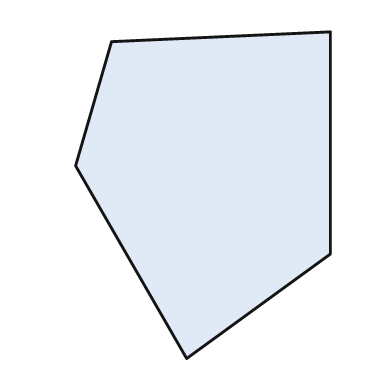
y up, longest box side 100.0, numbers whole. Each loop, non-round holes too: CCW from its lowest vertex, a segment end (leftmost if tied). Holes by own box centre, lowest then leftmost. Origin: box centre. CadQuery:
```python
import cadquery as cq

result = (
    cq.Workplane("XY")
    .moveTo(-5.0, -50.0)
    .lineTo(39.0, -18.0)
    .lineTo(39.0, 50.0)
    .lineTo(-28.0, 47.0)
    .lineTo(-39.0, 9.0)
    .close()
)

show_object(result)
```